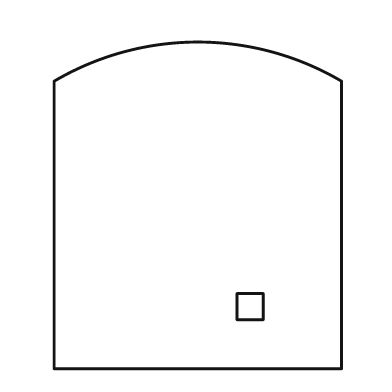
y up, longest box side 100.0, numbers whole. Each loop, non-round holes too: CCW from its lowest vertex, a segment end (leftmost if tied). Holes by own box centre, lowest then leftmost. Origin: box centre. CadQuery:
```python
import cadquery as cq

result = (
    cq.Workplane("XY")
    .moveTo(-44.0, -50.0)
    .lineTo(44.0, -50.0)
    .lineTo(44.0, 38.0)
    .threePointArc((0.0, 50.0), (-44.0, 38.0))
    .close()
    .moveTo(12.0, -35.0)
    .lineTo(20.0, -35.0)
    .lineTo(20.0, -27.0)
    .lineTo(12.0, -27.0)
    .close()
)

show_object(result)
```